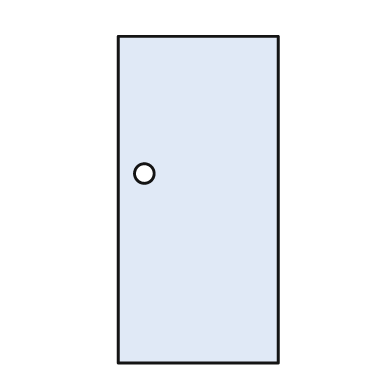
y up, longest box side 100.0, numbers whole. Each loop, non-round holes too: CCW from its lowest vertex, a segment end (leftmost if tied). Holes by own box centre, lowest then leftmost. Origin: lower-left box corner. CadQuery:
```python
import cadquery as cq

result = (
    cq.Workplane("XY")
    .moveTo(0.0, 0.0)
    .lineTo(49.0, 0.0)
    .lineTo(49.0, 100.0)
    .lineTo(0.0, 100.0)
    .close()
    .moveTo(8.0, 58.0)
    .circle(3.0)
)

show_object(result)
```